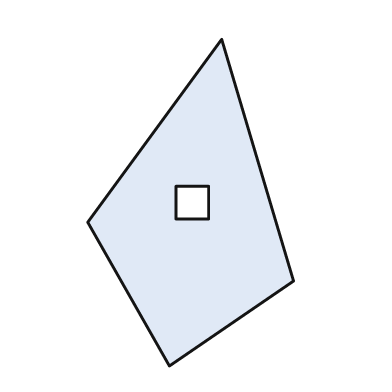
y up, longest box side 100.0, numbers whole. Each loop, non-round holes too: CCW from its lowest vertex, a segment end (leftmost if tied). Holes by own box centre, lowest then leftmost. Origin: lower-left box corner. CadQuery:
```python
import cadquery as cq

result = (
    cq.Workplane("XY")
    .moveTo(25.0, 0.0)
    .lineTo(63.0, 26.0)
    .lineTo(41.0, 100.0)
    .lineTo(0.0, 44.0)
    .close()
    .moveTo(27.0, 45.0)
    .lineTo(37.0, 45.0)
    .lineTo(37.0, 55.0)
    .lineTo(27.0, 55.0)
    .close()
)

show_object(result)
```